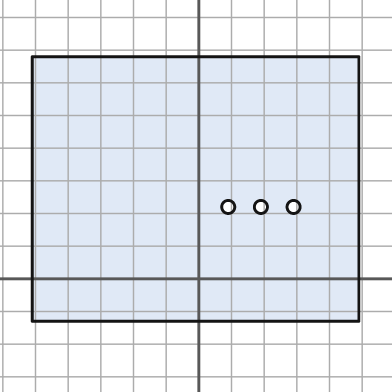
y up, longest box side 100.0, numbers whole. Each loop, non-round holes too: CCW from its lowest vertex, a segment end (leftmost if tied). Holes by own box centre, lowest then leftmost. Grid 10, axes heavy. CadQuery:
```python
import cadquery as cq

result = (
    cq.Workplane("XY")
    .moveTo(-51.0, -13.0)
    .lineTo(49.0, -13.0)
    .lineTo(49.0, 68.0)
    .lineTo(-51.0, 68.0)
    .close()
    .moveTo(9.0, 22.0)
    .circle(2.0)
    .moveTo(19.0, 22.0)
    .circle(2.0)
    .moveTo(29.0, 22.0)
    .circle(2.0)
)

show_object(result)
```